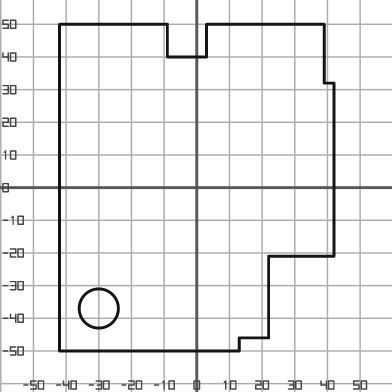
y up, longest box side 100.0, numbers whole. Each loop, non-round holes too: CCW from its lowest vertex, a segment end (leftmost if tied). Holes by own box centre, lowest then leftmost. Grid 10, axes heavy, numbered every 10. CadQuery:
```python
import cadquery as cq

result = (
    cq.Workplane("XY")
    .moveTo(-42.0, -50.0)
    .lineTo(13.0, -50.0)
    .lineTo(13.0, -46.0)
    .lineTo(22.0, -46.0)
    .lineTo(22.0, -21.0)
    .lineTo(42.0, -21.0)
    .lineTo(42.0, 32.0)
    .lineTo(39.0, 32.0)
    .lineTo(39.0, 50.0)
    .lineTo(3.0, 50.0)
    .lineTo(3.0, 40.0)
    .lineTo(-9.0, 40.0)
    .lineTo(-9.0, 50.0)
    .lineTo(-42.0, 50.0)
    .close()
    .moveTo(-30.0, -37.0)
    .circle(6.0)
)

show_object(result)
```